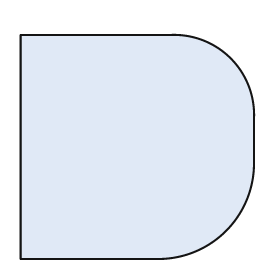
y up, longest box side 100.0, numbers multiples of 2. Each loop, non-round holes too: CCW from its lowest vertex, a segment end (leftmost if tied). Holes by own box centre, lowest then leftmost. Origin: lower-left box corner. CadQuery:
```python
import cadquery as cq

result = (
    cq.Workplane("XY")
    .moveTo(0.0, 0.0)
    .lineTo(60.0, 0.0)
    .threePointArc((88.0, 12.0), (100.0, 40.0))
    .lineTo(100.0, 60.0)
    .threePointArc((90.0, 86.0), (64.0, 96.0))
    .lineTo(0.0, 96.0)
    .close()
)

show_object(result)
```